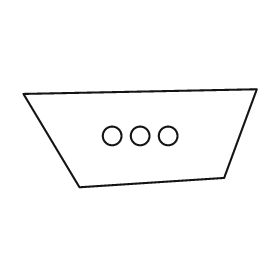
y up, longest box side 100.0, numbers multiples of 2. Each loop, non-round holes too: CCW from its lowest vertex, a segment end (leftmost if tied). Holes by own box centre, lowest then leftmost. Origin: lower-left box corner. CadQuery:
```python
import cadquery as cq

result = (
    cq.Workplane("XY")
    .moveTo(24.0, 0.0)
    .lineTo(86.0, 4.0)
    .lineTo(100.0, 42.0)
    .lineTo(0.0, 40.0)
    .close()
    .moveTo(38.0, 22.0)
    .circle(4.0)
    .moveTo(50.0, 22.0)
    .circle(4.0)
    .moveTo(62.0, 22.0)
    .circle(4.0)
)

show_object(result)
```